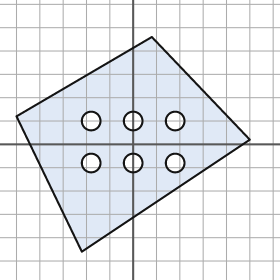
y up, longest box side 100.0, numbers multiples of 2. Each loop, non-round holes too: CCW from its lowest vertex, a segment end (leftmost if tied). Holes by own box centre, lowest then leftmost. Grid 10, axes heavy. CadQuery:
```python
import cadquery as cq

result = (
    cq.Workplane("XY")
    .moveTo(-22.0, -46.0)
    .lineTo(50.0, 2.0)
    .lineTo(8.0, 46.0)
    .lineTo(-50.0, 12.0)
    .close()
    .moveTo(-18.0, -8.0)
    .circle(4.0)
    .moveTo(0.0, -8.0)
    .circle(4.0)
    .moveTo(18.0, -8.0)
    .circle(4.0)
    .moveTo(-18.0, 10.0)
    .circle(4.0)
    .moveTo(0.0, 10.0)
    .circle(4.0)
    .moveTo(18.0, 10.0)
    .circle(4.0)
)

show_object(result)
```